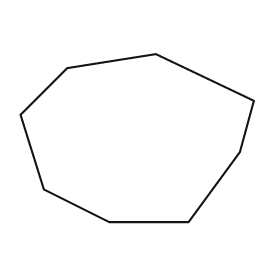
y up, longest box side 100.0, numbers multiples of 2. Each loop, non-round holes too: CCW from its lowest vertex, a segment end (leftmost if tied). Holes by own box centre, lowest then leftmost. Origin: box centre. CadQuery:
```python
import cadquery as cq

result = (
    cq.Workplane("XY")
    .moveTo(-12.0, -36.0)
    .lineTo(22.0, -36.0)
    .lineTo(44.0, -6.0)
    .lineTo(50.0, 16.0)
    .lineTo(8.0, 36.0)
    .lineTo(-30.0, 30.0)
    .lineTo(-50.0, 10.0)
    .lineTo(-40.0, -22.0)
    .close()
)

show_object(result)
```